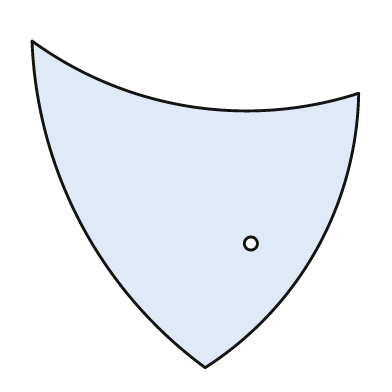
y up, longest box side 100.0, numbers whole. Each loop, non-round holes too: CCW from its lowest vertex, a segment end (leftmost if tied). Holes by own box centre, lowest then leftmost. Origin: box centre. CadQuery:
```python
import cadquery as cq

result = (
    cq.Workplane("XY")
    .moveTo(3.0, -50.0)
    .threePointArc((37.0, -14.0), (50.0, 34.0))
    .threePointArc((-2.0, 30.0), (-50.0, 50.0))
    .threePointArc((-35.0, -6.0), (3.0, -50.0))
    .close()
    .moveTo(17.0, -12.0)
    .circle(2.0)
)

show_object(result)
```